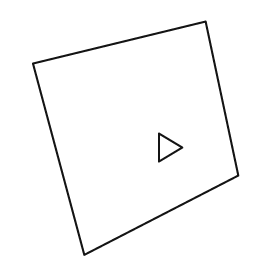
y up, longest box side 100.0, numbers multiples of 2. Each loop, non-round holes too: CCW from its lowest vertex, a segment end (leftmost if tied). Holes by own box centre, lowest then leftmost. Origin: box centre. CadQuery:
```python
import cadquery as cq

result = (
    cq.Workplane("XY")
    .moveTo(-22.0, -50.0)
    .lineTo(44.0, -16.0)
    .lineTo(30.0, 50.0)
    .lineTo(-44.0, 32.0)
    .close()
    .moveTo(10.0, -10.0)
    .lineTo(20.0, -4.0)
    .lineTo(10.0, 2.0)
    .close()
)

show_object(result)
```